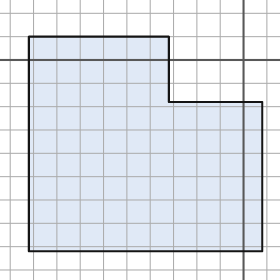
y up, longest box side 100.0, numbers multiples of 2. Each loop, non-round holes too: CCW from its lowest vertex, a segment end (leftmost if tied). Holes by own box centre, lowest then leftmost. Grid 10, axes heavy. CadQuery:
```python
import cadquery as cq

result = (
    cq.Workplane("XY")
    .moveTo(-92.0, -82.0)
    .lineTo(8.0, -82.0)
    .lineTo(8.0, -18.0)
    .lineTo(-32.0, -18.0)
    .lineTo(-32.0, 10.0)
    .lineTo(-92.0, 10.0)
    .close()
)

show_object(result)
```